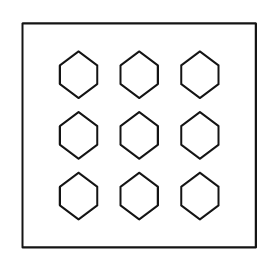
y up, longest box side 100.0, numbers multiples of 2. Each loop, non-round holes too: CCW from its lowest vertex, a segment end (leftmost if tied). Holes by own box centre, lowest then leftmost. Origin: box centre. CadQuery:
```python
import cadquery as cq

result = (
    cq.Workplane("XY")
    .moveTo(-50.0, -48.0)
    .lineTo(50.0, -48.0)
    .lineTo(50.0, 48.0)
    .lineTo(-50.0, 48.0)
    .close()
    .moveTo(-26.0, -36.0)
    .lineTo(-18.0, -30.0)
    .lineTo(-18.0, -22.0)
    .lineTo(-26.0, -16.0)
    .lineTo(-34.0, -22.0)
    .lineTo(-34.0, -30.0)
    .close()
    .moveTo(0.0, -36.0)
    .lineTo(8.0, -30.0)
    .lineTo(8.0, -22.0)
    .lineTo(0.0, -16.0)
    .lineTo(-8.0, -22.0)
    .lineTo(-8.0, -30.0)
    .close()
    .moveTo(26.0, -36.0)
    .lineTo(34.0, -30.0)
    .lineTo(34.0, -22.0)
    .lineTo(26.0, -16.0)
    .lineTo(18.0, -22.0)
    .lineTo(18.0, -30.0)
    .close()
    .moveTo(-26.0, -10.0)
    .lineTo(-18.0, -4.0)
    .lineTo(-18.0, 4.0)
    .lineTo(-26.0, 10.0)
    .lineTo(-34.0, 4.0)
    .lineTo(-34.0, -4.0)
    .close()
    .moveTo(0.0, -10.0)
    .lineTo(8.0, -4.0)
    .lineTo(8.0, 4.0)
    .lineTo(0.0, 10.0)
    .lineTo(-8.0, 4.0)
    .lineTo(-8.0, -4.0)
    .close()
    .moveTo(26.0, -10.0)
    .lineTo(34.0, -4.0)
    .lineTo(34.0, 4.0)
    .lineTo(26.0, 10.0)
    .lineTo(18.0, 4.0)
    .lineTo(18.0, -4.0)
    .close()
    .moveTo(-26.0, 16.0)
    .lineTo(-18.0, 22.0)
    .lineTo(-18.0, 30.0)
    .lineTo(-26.0, 36.0)
    .lineTo(-34.0, 30.0)
    .lineTo(-34.0, 22.0)
    .close()
    .moveTo(0.0, 16.0)
    .lineTo(8.0, 22.0)
    .lineTo(8.0, 30.0)
    .lineTo(0.0, 36.0)
    .lineTo(-8.0, 30.0)
    .lineTo(-8.0, 22.0)
    .close()
    .moveTo(26.0, 16.0)
    .lineTo(34.0, 22.0)
    .lineTo(34.0, 30.0)
    .lineTo(26.0, 36.0)
    .lineTo(18.0, 30.0)
    .lineTo(18.0, 22.0)
    .close()
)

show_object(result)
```